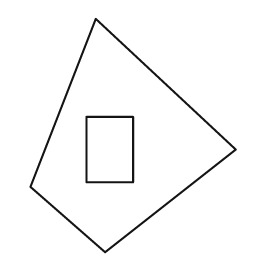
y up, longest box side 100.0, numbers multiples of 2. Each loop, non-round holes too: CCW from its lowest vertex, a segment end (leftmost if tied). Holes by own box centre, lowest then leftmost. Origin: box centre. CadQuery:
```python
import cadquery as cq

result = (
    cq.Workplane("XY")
    .moveTo(-12.0, -50.0)
    .lineTo(44.0, -6.0)
    .lineTo(-16.0, 50.0)
    .lineTo(-44.0, -22.0)
    .close()
    .moveTo(-20.0, -20.0)
    .lineTo(0.0, -20.0)
    .lineTo(0.0, 8.0)
    .lineTo(-20.0, 8.0)
    .close()
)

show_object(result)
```